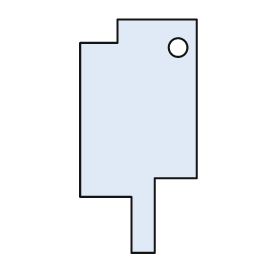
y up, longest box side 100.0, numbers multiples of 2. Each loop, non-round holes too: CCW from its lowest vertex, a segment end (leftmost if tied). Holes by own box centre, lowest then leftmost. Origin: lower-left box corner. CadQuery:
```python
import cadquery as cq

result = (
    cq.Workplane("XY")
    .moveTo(22.0, 0.0)
    .lineTo(32.0, 0.0)
    .lineTo(32.0, 32.0)
    .lineTo(50.0, 32.0)
    .lineTo(50.0, 100.0)
    .lineTo(16.0, 100.0)
    .lineTo(16.0, 90.0)
    .lineTo(0.0, 90.0)
    .lineTo(0.0, 24.0)
    .lineTo(22.0, 24.0)
    .close()
    .moveTo(42.0, 88.0)
    .circle(4.0)
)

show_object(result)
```